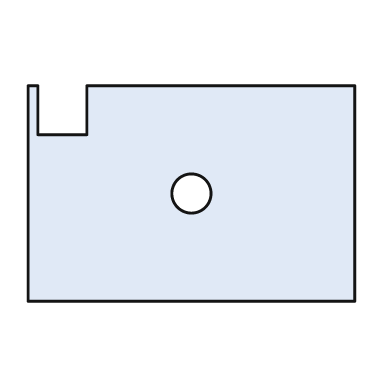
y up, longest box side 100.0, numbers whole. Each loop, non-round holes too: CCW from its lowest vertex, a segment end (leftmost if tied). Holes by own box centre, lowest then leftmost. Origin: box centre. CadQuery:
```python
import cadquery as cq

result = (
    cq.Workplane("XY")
    .moveTo(-50.0, -33.0)
    .lineTo(50.0, -33.0)
    .lineTo(50.0, 33.0)
    .lineTo(-32.0, 33.0)
    .lineTo(-32.0, 18.0)
    .lineTo(-47.0, 18.0)
    .lineTo(-47.0, 33.0)
    .lineTo(-50.0, 33.0)
    .close()
    .moveTo(0.0, 0.0)
    .circle(6.0)
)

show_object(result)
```